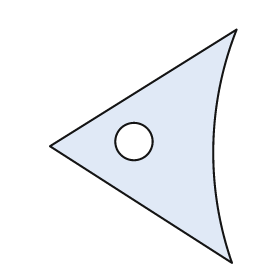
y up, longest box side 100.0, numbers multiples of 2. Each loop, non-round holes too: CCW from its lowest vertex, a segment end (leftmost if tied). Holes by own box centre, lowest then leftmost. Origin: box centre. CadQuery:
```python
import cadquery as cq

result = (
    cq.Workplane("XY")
    .moveTo(38.0, -50.0)
    .threePointArc((30.0, 0.0), (40.0, 50.0))
    .lineTo(-40.0, 0.0)
    .close()
    .moveTo(-4.0, 2.0)
    .circle(8.0)
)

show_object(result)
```